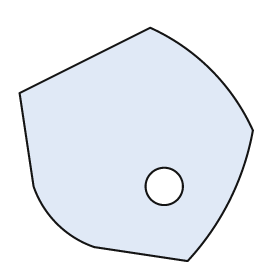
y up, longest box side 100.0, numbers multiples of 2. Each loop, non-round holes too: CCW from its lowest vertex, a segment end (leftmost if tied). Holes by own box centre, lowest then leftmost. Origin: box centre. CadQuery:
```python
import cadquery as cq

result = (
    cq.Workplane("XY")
    .moveTo(22.0, -50.0)
    .threePointArc((40.0, -24.0), (50.0, 6.0))
    .threePointArc((32.0, 32.0), (6.0, 50.0))
    .lineTo(-50.0, 22.0)
    .lineTo(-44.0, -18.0)
    .threePointArc((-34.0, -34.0), (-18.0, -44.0))
    .close()
    .moveTo(12.0, -18.0)
    .circle(8.0)
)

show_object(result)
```